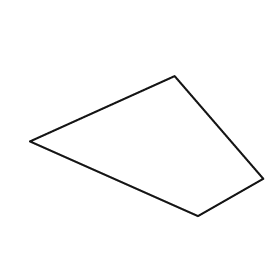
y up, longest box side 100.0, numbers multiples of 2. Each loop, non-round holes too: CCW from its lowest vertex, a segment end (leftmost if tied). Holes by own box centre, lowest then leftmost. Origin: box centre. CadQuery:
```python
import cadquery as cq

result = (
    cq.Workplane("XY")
    .moveTo(22.0, -30.0)
    .lineTo(50.0, -14.0)
    .lineTo(12.0, 30.0)
    .lineTo(-50.0, 2.0)
    .close()
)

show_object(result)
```